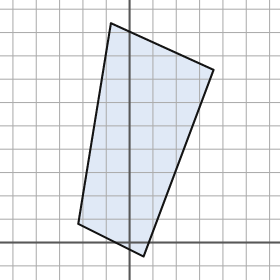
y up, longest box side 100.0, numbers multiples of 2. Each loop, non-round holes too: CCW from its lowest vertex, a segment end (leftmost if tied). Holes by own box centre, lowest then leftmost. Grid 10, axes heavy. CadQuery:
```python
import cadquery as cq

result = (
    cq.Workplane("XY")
    .moveTo(6.0, -6.0)
    .lineTo(36.0, 74.0)
    .lineTo(-8.0, 94.0)
    .lineTo(-22.0, 8.0)
    .close()
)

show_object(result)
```